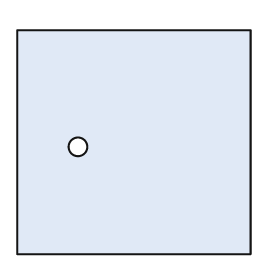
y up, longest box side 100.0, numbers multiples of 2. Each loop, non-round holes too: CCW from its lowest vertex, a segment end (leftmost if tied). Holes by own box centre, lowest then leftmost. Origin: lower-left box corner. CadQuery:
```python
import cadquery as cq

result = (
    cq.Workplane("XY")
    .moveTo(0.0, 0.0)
    .lineTo(100.0, 0.0)
    .lineTo(100.0, 96.0)
    .lineTo(0.0, 96.0)
    .close()
    .moveTo(26.0, 46.0)
    .circle(4.0)
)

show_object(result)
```